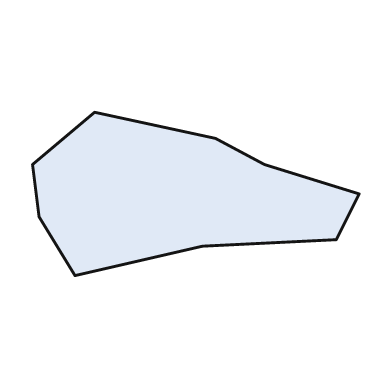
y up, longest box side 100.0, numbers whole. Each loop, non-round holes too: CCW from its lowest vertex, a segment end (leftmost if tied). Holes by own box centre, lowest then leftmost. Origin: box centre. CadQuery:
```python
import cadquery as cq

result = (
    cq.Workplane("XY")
    .moveTo(-37.0, -25.0)
    .lineTo(2.0, -16.0)
    .lineTo(43.0, -14.0)
    .lineTo(50.0, 0.0)
    .lineTo(21.0, 9.0)
    .lineTo(6.0, 17.0)
    .lineTo(-31.0, 25.0)
    .lineTo(-50.0, 9.0)
    .lineTo(-48.0, -7.0)
    .close()
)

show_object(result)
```